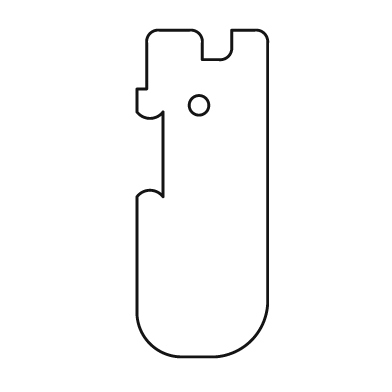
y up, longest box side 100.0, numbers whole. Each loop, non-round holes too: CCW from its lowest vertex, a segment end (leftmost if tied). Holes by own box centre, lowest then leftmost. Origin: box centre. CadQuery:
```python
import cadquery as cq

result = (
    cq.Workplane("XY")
    .moveTo(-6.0, -50.0)
    .lineTo(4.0, -50.0)
    .threePointArc((15.0, -45.0), (20.0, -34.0))
    .lineTo(20.0, 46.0)
    .threePointArc((19.0, 49.0), (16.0, 50.0))
    .lineTo(9.0, 50.0)
    .lineTo(9.0, 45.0)
    .threePointArc((8.0, 42.0), (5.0, 41.0))
    .lineTo(0.0, 41.0)
    .lineTo(0.0, 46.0)
    .threePointArc((-1.0, 49.0), (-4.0, 50.0))
    .lineTo(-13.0, 50.0)
    .threePointArc((-16.0, 49.0), (-17.0, 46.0))
    .lineTo(-17.0, 32.0)
    .lineTo(-20.0, 32.0)
    .lineTo(-20.0, 25.0)
    .threePointArc((-16.0, 23.0), (-12.0, 25.0))
    .lineTo(-12.0, -1.0)
    .threePointArc((-16.0, 1.0), (-20.0, -1.0))
    .lineTo(-20.0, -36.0)
    .threePointArc((-16.0, -46.0), (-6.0, -50.0))
    .close()
    .moveTo(-1.0, 27.0)
    .circle(3.0)
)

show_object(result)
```